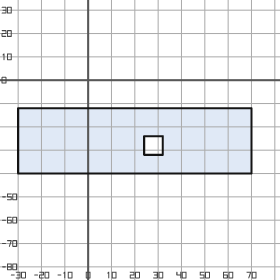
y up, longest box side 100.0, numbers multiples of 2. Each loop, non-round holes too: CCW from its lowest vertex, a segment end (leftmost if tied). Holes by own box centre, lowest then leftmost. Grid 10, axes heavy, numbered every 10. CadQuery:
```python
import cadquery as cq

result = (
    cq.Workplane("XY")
    .moveTo(-30.0, -40.0)
    .lineTo(70.0, -40.0)
    .lineTo(70.0, -12.0)
    .lineTo(-30.0, -12.0)
    .close()
    .moveTo(24.0, -32.0)
    .lineTo(32.0, -32.0)
    .lineTo(32.0, -24.0)
    .lineTo(24.0, -24.0)
    .close()
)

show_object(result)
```